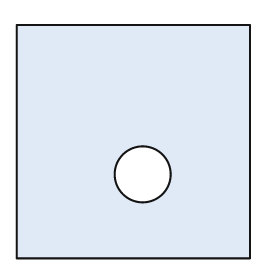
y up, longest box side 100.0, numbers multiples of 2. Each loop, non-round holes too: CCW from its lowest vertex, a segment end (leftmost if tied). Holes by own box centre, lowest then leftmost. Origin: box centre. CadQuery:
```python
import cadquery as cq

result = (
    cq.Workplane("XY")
    .moveTo(-50.0, -50.0)
    .lineTo(50.0, -50.0)
    .lineTo(50.0, 50.0)
    .lineTo(-50.0, 50.0)
    .close()
    .moveTo(4.0, -14.0)
    .circle(12.0)
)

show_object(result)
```